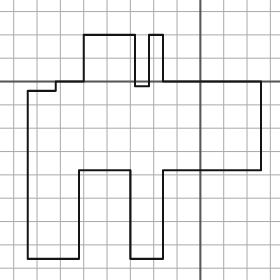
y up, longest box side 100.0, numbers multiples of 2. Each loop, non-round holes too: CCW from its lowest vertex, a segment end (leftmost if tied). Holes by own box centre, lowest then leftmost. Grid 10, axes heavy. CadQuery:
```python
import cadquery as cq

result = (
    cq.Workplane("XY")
    .moveTo(-74.0, -76.0)
    .lineTo(-52.0, -76.0)
    .lineTo(-52.0, -38.0)
    .lineTo(-30.0, -38.0)
    .lineTo(-30.0, -76.0)
    .lineTo(-16.0, -76.0)
    .lineTo(-16.0, -38.0)
    .lineTo(26.0, -38.0)
    .lineTo(26.0, 0.0)
    .lineTo(-16.0, 0.0)
    .lineTo(-16.0, 20.0)
    .lineTo(-22.0, 20.0)
    .lineTo(-22.0, -2.0)
    .lineTo(-28.0, -2.0)
    .lineTo(-28.0, 20.0)
    .lineTo(-50.0, 20.0)
    .lineTo(-50.0, 0.0)
    .lineTo(-62.0, 0.0)
    .lineTo(-62.0, -4.0)
    .lineTo(-74.0, -4.0)
    .close()
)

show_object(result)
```